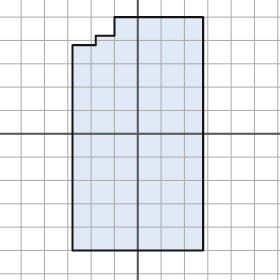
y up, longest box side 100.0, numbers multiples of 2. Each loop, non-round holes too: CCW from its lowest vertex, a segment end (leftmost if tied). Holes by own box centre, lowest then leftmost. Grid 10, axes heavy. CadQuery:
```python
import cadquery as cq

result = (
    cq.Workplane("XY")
    .moveTo(-28.0, -50.0)
    .lineTo(28.0, -50.0)
    .lineTo(28.0, 50.0)
    .lineTo(-10.0, 50.0)
    .lineTo(-10.0, 42.0)
    .lineTo(-18.0, 42.0)
    .lineTo(-18.0, 38.0)
    .lineTo(-28.0, 38.0)
    .close()
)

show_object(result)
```